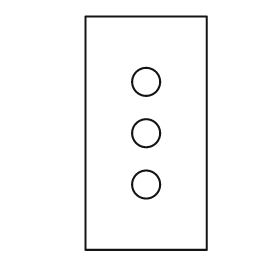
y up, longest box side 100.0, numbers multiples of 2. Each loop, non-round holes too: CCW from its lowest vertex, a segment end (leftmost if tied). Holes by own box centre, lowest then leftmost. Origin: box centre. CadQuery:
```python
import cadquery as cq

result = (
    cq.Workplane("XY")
    .moveTo(-26.0, -50.0)
    .lineTo(26.0, -50.0)
    .lineTo(26.0, 50.0)
    .lineTo(-26.0, 50.0)
    .close()
    .moveTo(0.0, -22.0)
    .circle(6.0)
    .moveTo(0.0, 0.0)
    .circle(6.0)
    .moveTo(0.0, 22.0)
    .circle(6.0)
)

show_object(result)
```